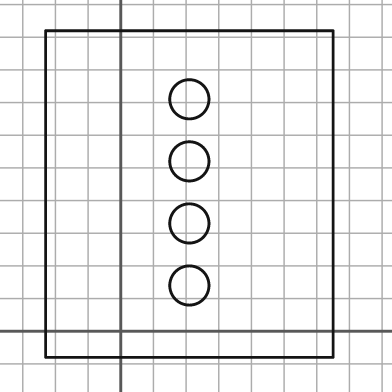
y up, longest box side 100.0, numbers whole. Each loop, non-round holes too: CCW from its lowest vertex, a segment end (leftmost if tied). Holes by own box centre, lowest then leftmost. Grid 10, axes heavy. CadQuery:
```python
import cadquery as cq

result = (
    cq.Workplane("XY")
    .moveTo(-23.0, -8.0)
    .lineTo(65.0, -8.0)
    .lineTo(65.0, 92.0)
    .lineTo(-23.0, 92.0)
    .close()
    .moveTo(21.0, 14.0)
    .circle(6.0)
    .moveTo(21.0, 33.0)
    .circle(6.0)
    .moveTo(21.0, 52.0)
    .circle(6.0)
    .moveTo(21.0, 71.0)
    .circle(6.0)
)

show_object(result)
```